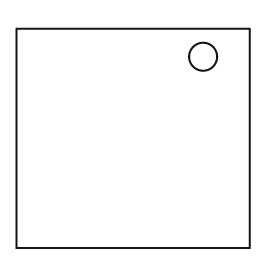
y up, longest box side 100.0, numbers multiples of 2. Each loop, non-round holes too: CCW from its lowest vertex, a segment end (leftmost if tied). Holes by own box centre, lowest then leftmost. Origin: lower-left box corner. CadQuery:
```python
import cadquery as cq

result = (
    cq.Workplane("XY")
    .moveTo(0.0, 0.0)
    .lineTo(100.0, 0.0)
    .lineTo(100.0, 94.0)
    .lineTo(0.0, 94.0)
    .close()
    .moveTo(80.0, 82.0)
    .circle(6.0)
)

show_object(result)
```